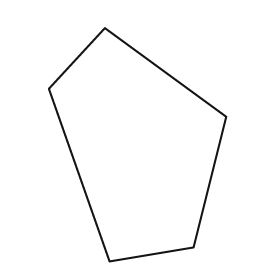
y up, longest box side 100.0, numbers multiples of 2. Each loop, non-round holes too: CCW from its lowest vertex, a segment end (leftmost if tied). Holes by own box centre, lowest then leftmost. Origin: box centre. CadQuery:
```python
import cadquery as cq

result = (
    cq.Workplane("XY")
    .moveTo(-12.0, -50.0)
    .lineTo(24.0, -44.0)
    .lineTo(38.0, 12.0)
    .lineTo(-14.0, 50.0)
    .lineTo(-38.0, 24.0)
    .close()
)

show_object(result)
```